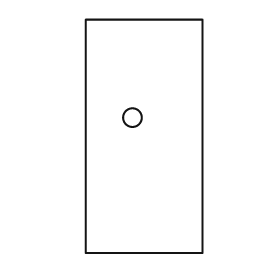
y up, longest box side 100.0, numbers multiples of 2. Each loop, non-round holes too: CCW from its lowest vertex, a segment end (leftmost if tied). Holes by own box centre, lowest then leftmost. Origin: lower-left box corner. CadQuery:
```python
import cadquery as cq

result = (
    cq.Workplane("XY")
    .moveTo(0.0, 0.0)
    .lineTo(50.0, 0.0)
    .lineTo(50.0, 100.0)
    .lineTo(0.0, 100.0)
    .close()
    .moveTo(20.0, 58.0)
    .circle(4.0)
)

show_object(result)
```